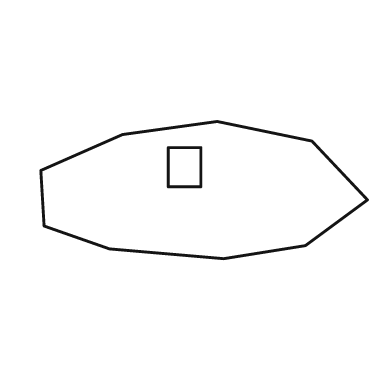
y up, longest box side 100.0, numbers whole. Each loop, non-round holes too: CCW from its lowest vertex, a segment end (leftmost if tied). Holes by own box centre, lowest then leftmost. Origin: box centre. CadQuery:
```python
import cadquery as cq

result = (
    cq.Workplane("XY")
    .moveTo(6.0, -21.0)
    .lineTo(31.0, -17.0)
    .lineTo(50.0, -3.0)
    .lineTo(33.0, 15.0)
    .lineTo(4.0, 21.0)
    .lineTo(-25.0, 17.0)
    .lineTo(-50.0, 6.0)
    .lineTo(-49.0, -11.0)
    .lineTo(-29.0, -18.0)
    .close()
    .moveTo(-11.0, 1.0)
    .lineTo(-1.0, 1.0)
    .lineTo(-1.0, 13.0)
    .lineTo(-11.0, 13.0)
    .close()
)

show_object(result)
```